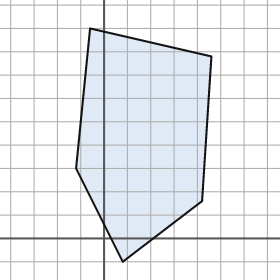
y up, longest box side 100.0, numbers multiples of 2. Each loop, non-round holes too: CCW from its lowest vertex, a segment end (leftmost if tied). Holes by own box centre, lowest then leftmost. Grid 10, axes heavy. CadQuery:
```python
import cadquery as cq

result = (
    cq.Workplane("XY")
    .moveTo(8.0, -10.0)
    .lineTo(42.0, 16.0)
    .lineTo(46.0, 78.0)
    .lineTo(-6.0, 90.0)
    .lineTo(-12.0, 30.0)
    .close()
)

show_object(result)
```